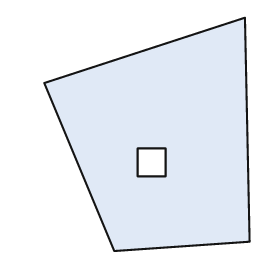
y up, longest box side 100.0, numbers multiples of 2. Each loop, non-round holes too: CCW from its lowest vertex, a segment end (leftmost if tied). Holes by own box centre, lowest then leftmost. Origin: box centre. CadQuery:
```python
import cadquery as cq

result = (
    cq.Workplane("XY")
    .moveTo(-14.0, -50.0)
    .lineTo(44.0, -46.0)
    .lineTo(42.0, 50.0)
    .lineTo(-44.0, 22.0)
    .close()
    .moveTo(-4.0, -18.0)
    .lineTo(8.0, -18.0)
    .lineTo(8.0, -6.0)
    .lineTo(-4.0, -6.0)
    .close()
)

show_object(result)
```